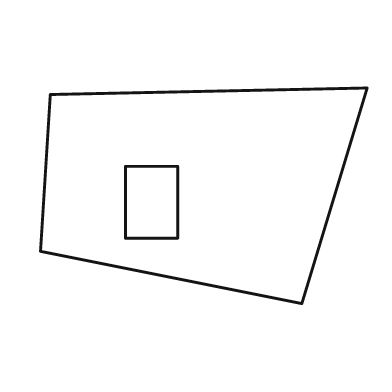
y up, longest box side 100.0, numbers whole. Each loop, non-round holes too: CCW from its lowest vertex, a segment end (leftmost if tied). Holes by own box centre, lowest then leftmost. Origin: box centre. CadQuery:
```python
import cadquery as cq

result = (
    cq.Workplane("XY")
    .moveTo(30.0, -33.0)
    .lineTo(50.0, 33.0)
    .lineTo(-47.0, 31.0)
    .lineTo(-50.0, -17.0)
    .close()
    .moveTo(-24.0, -13.0)
    .lineTo(-8.0, -13.0)
    .lineTo(-8.0, 9.0)
    .lineTo(-24.0, 9.0)
    .close()
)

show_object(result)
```